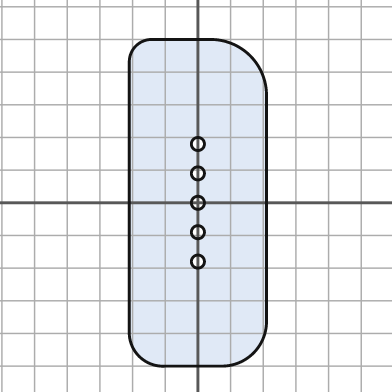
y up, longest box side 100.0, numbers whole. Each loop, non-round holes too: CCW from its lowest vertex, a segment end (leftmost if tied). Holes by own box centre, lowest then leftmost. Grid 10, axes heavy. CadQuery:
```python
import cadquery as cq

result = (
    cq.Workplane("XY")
    .moveTo(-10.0, -50.0)
    .lineTo(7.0, -50.0)
    .threePointArc((17.0, -46.0), (21.0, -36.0))
    .lineTo(21.0, 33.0)
    .threePointArc((16.0, 45.0), (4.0, 50.0))
    .lineTo(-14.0, 50.0)
    .threePointArc((-19.0, 48.0), (-21.0, 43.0))
    .lineTo(-21.0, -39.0)
    .threePointArc((-18.0, -47.0), (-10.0, -50.0))
    .close()
    .moveTo(0.0, -18.0)
    .circle(2.0)
    .moveTo(0.0, -9.0)
    .circle(2.0)
    .moveTo(0.0, 0.0)
    .circle(2.0)
    .moveTo(0.0, 9.0)
    .circle(2.0)
    .moveTo(0.0, 18.0)
    .circle(2.0)
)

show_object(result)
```